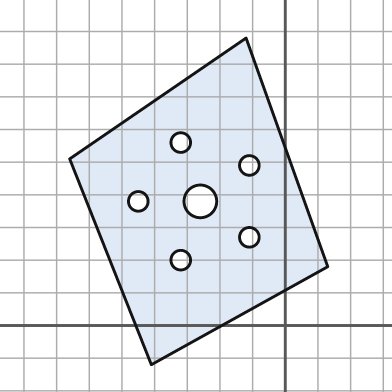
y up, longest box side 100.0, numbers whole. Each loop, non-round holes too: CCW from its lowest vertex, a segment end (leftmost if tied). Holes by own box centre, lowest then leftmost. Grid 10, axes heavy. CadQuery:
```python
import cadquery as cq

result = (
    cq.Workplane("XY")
    .moveTo(-41.0, -12.0)
    .lineTo(13.0, 18.0)
    .lineTo(-12.0, 88.0)
    .lineTo(-66.0, 51.0)
    .close()
    .moveTo(-32.0, 20.0)
    .circle(3.0)
    .moveTo(-11.0, 27.0)
    .circle(3.0)
    .moveTo(-45.0, 38.0)
    .circle(3.0)
    .moveTo(-26.0, 38.0)
    .circle(5.0)
    .moveTo(-11.0, 49.0)
    .circle(3.0)
    .moveTo(-32.0, 56.0)
    .circle(3.0)
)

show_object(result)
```